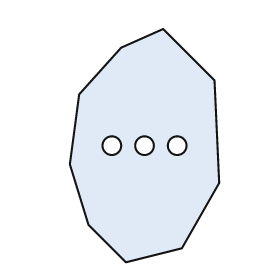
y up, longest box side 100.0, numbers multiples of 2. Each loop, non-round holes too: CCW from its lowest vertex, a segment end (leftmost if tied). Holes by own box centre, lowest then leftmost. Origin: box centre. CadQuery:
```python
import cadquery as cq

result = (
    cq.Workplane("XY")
    .moveTo(-8.0, -50.0)
    .lineTo(16.0, -44.0)
    .lineTo(32.0, -16.0)
    .lineTo(30.0, 28.0)
    .lineTo(8.0, 50.0)
    .lineTo(-10.0, 42.0)
    .lineTo(-28.0, 22.0)
    .lineTo(-32.0, -8.0)
    .lineTo(-24.0, -34.0)
    .close()
    .moveTo(-14.0, 0.0)
    .circle(4.0)
    .moveTo(0.0, 0.0)
    .circle(4.0)
    .moveTo(14.0, 0.0)
    .circle(4.0)
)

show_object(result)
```